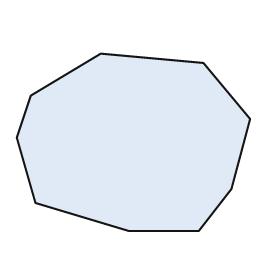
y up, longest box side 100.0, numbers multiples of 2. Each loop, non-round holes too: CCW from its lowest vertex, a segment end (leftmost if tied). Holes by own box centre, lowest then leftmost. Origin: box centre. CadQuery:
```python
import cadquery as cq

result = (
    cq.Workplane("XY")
    .moveTo(-2.0, -38.0)
    .lineTo(28.0, -38.0)
    .lineTo(42.0, -20.0)
    .lineTo(50.0, 10.0)
    .lineTo(30.0, 34.0)
    .lineTo(-14.0, 38.0)
    .lineTo(-44.0, 20.0)
    .lineTo(-50.0, 2.0)
    .lineTo(-42.0, -26.0)
    .close()
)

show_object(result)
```